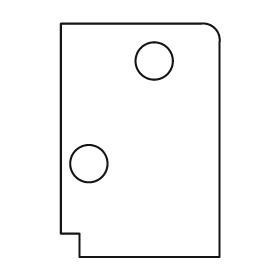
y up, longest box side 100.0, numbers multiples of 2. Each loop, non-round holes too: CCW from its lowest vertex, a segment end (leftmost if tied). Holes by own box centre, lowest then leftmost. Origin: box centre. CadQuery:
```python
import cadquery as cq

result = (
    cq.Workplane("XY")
    .moveTo(-26.0, -50.0)
    .lineTo(34.0, -50.0)
    .lineTo(34.0, 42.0)
    .threePointArc((32.0, 48.0), (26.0, 50.0))
    .lineTo(-34.0, 50.0)
    .lineTo(-34.0, -40.0)
    .lineTo(-26.0, -40.0)
    .close()
    .moveTo(-22.0, -10.0)
    .circle(8.0)
    .moveTo(6.0, 34.0)
    .circle(8.0)
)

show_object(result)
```